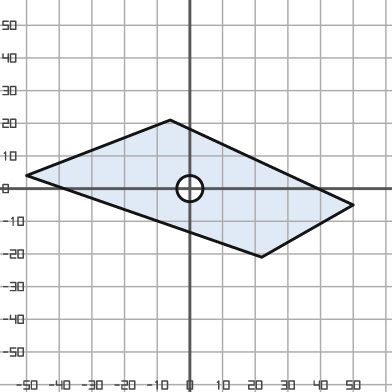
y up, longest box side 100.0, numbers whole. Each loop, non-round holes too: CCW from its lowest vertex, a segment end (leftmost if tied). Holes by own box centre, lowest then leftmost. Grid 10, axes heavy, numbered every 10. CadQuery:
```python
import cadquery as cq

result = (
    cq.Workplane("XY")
    .moveTo(22.0, -21.0)
    .lineTo(50.0, -5.0)
    .lineTo(-6.0, 21.0)
    .lineTo(-50.0, 4.0)
    .close()
    .moveTo(0.0, 0.0)
    .circle(4.0)
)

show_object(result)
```